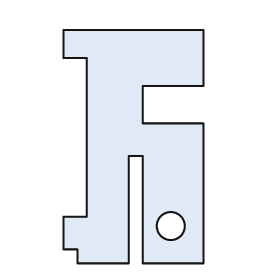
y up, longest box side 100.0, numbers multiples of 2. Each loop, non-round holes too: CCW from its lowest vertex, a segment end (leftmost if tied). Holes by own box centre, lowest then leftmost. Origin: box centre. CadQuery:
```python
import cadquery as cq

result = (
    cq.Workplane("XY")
    .moveTo(-24.0, -50.0)
    .lineTo(-2.0, -50.0)
    .lineTo(-2.0, -4.0)
    .lineTo(4.0, -4.0)
    .lineTo(4.0, -50.0)
    .lineTo(30.0, -50.0)
    .lineTo(30.0, 10.0)
    .lineTo(4.0, 10.0)
    .lineTo(4.0, 26.0)
    .lineTo(30.0, 26.0)
    .lineTo(30.0, 50.0)
    .lineTo(-30.0, 50.0)
    .lineTo(-30.0, 38.0)
    .lineTo(-20.0, 38.0)
    .lineTo(-20.0, -30.0)
    .lineTo(-30.0, -30.0)
    .lineTo(-30.0, -44.0)
    .lineTo(-24.0, -44.0)
    .close()
    .moveTo(16.0, -34.0)
    .circle(6.0)
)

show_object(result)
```